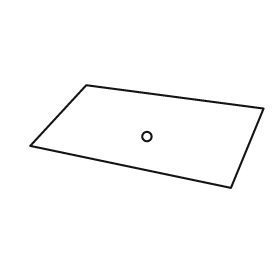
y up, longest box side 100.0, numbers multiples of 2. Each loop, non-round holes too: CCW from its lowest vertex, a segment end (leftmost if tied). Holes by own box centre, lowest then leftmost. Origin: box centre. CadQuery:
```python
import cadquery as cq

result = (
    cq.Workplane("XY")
    .moveTo(36.0, -22.0)
    .lineTo(50.0, 12.0)
    .lineTo(-26.0, 22.0)
    .lineTo(-50.0, -4.0)
    .close()
    .moveTo(0.0, 0.0)
    .circle(2.0)
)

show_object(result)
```